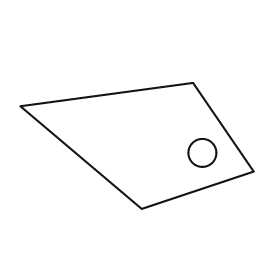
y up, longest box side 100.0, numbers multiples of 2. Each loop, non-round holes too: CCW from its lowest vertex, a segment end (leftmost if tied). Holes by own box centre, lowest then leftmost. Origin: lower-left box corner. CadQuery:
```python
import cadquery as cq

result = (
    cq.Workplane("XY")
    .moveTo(52.0, 0.0)
    .lineTo(100.0, 16.0)
    .lineTo(74.0, 54.0)
    .lineTo(0.0, 44.0)
    .close()
    .moveTo(78.0, 24.0)
    .circle(6.0)
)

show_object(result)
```